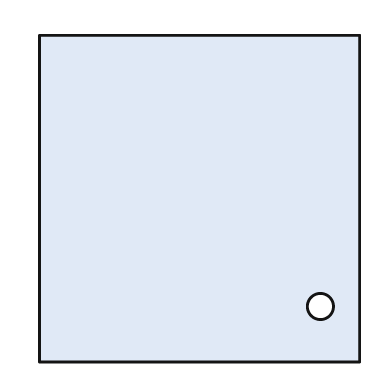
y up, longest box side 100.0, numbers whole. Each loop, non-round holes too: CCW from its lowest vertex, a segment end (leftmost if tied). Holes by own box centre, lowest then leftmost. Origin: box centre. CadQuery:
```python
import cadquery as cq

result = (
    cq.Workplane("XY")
    .moveTo(-49.0, -50.0)
    .lineTo(49.0, -50.0)
    .lineTo(49.0, 50.0)
    .lineTo(-49.0, 50.0)
    .close()
    .moveTo(37.0, -33.0)
    .circle(4.0)
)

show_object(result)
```